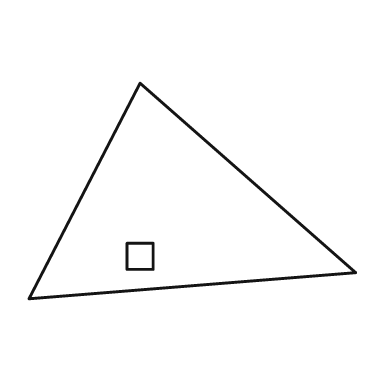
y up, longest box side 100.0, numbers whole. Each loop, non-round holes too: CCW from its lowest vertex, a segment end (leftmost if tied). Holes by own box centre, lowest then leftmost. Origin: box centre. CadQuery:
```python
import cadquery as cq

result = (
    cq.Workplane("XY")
    .moveTo(-50.0, -33.0)
    .lineTo(50.0, -25.0)
    .lineTo(-16.0, 33.0)
    .close()
    .moveTo(-20.0, -24.0)
    .lineTo(-12.0, -24.0)
    .lineTo(-12.0, -16.0)
    .lineTo(-20.0, -16.0)
    .close()
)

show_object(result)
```